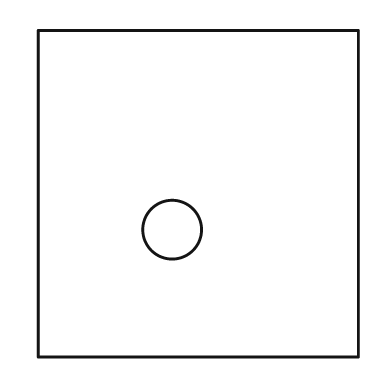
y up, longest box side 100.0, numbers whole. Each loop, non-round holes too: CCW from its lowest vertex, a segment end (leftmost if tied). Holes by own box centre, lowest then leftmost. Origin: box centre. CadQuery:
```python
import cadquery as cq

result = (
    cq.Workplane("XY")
    .moveTo(-49.0, -50.0)
    .lineTo(49.0, -50.0)
    .lineTo(49.0, 50.0)
    .lineTo(-49.0, 50.0)
    .close()
    .moveTo(-8.0, -11.0)
    .circle(9.0)
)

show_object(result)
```